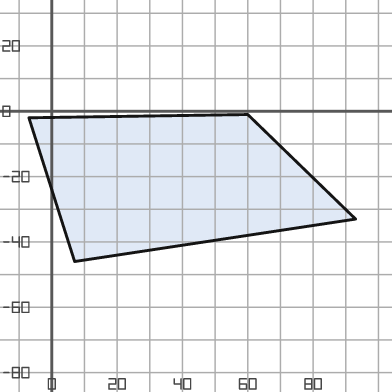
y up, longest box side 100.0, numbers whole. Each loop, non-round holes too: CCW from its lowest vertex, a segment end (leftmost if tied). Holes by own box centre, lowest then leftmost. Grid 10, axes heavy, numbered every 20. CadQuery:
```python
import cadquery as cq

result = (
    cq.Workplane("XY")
    .moveTo(7.0, -46.0)
    .lineTo(93.0, -33.0)
    .lineTo(60.0, -1.0)
    .lineTo(-7.0, -2.0)
    .close()
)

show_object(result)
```